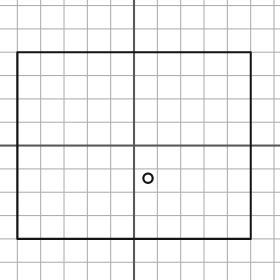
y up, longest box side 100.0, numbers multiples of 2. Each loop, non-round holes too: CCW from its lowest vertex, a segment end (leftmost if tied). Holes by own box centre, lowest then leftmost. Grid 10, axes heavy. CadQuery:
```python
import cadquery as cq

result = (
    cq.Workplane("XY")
    .moveTo(-50.0, -40.0)
    .lineTo(50.0, -40.0)
    .lineTo(50.0, 40.0)
    .lineTo(-50.0, 40.0)
    .close()
    .moveTo(6.0, -14.0)
    .circle(2.0)
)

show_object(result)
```